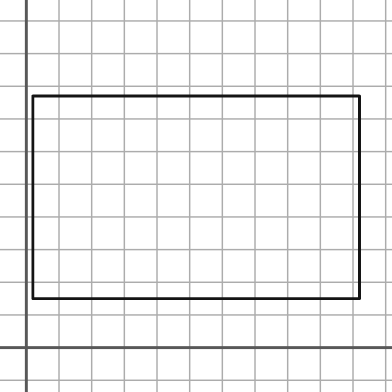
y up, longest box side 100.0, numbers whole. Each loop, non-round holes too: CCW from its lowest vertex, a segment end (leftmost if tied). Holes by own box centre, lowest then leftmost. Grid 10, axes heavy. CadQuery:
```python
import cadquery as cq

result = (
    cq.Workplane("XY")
    .moveTo(2.0, 15.0)
    .lineTo(102.0, 15.0)
    .lineTo(102.0, 77.0)
    .lineTo(2.0, 77.0)
    .close()
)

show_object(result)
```